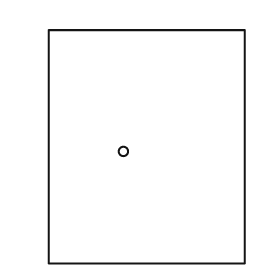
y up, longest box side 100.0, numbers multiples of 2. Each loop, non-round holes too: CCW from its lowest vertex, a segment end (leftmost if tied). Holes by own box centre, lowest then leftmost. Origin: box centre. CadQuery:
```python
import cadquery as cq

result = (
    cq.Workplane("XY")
    .moveTo(-42.0, -50.0)
    .lineTo(42.0, -50.0)
    .lineTo(42.0, 50.0)
    .lineTo(-42.0, 50.0)
    .close()
    .moveTo(-10.0, -2.0)
    .circle(2.0)
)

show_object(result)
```